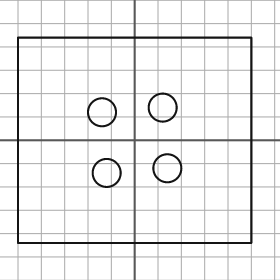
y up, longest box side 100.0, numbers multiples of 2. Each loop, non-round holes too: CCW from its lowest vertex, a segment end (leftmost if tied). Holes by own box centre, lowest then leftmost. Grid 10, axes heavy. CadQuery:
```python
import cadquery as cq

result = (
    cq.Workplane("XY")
    .moveTo(-50.0, -44.0)
    .lineTo(50.0, -44.0)
    .lineTo(50.0, 44.0)
    .lineTo(-50.0, 44.0)
    .close()
    .moveTo(-12.0, -14.0)
    .circle(6.0)
    .moveTo(14.0, -12.0)
    .circle(6.0)
    .moveTo(-14.0, 12.0)
    .circle(6.0)
    .moveTo(12.0, 14.0)
    .circle(6.0)
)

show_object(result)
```